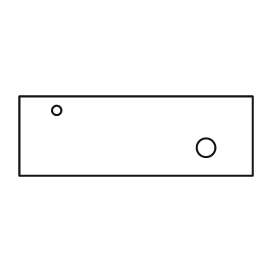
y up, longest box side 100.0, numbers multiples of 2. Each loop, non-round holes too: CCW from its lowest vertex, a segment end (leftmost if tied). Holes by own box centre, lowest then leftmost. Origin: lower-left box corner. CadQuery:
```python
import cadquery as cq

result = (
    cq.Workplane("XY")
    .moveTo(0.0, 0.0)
    .lineTo(100.0, 0.0)
    .lineTo(100.0, 34.0)
    .lineTo(0.0, 34.0)
    .close()
    .moveTo(80.0, 12.0)
    .circle(4.0)
    .moveTo(16.0, 28.0)
    .circle(2.0)
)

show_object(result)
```